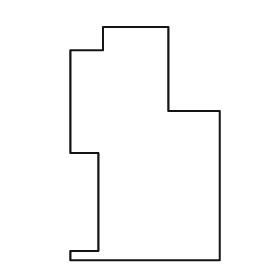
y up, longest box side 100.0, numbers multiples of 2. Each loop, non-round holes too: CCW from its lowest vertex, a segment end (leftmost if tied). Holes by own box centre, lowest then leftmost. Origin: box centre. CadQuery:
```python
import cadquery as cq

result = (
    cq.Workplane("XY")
    .moveTo(-32.0, -50.0)
    .lineTo(32.0, -50.0)
    .lineTo(32.0, 14.0)
    .lineTo(10.0, 14.0)
    .lineTo(10.0, 50.0)
    .lineTo(-18.0, 50.0)
    .lineTo(-18.0, 40.0)
    .lineTo(-32.0, 40.0)
    .lineTo(-32.0, -4.0)
    .lineTo(-20.0, -4.0)
    .lineTo(-20.0, -46.0)
    .lineTo(-32.0, -46.0)
    .close()
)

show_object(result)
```